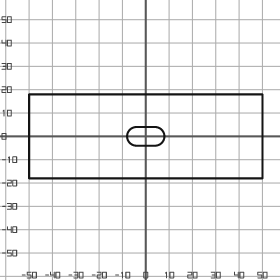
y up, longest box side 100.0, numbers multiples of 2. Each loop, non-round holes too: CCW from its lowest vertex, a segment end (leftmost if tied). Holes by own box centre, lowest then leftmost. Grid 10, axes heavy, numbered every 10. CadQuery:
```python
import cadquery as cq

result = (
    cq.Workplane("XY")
    .moveTo(-50.0, -18.0)
    .lineTo(50.0, -18.0)
    .lineTo(50.0, 18.0)
    .lineTo(-50.0, 18.0)
    .close()
    .moveTo(-4.0, -4.0)
    .lineTo(4.0, -4.0)
    .threePointArc((8.0, 0.0), (4.0, 4.0))
    .lineTo(-4.0, 4.0)
    .threePointArc((-8.0, 0.0), (-4.0, -4.0))
    .close()
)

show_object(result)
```